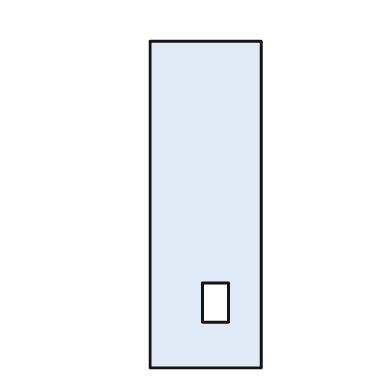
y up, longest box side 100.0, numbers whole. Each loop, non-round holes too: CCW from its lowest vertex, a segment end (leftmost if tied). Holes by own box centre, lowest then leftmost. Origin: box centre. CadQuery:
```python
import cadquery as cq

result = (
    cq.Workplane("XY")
    .moveTo(-17.0, -50.0)
    .lineTo(17.0, -50.0)
    .lineTo(17.0, 50.0)
    .lineTo(-17.0, 50.0)
    .close()
    .moveTo(-1.0, -36.0)
    .lineTo(7.0, -36.0)
    .lineTo(7.0, -24.0)
    .lineTo(-1.0, -24.0)
    .close()
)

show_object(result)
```